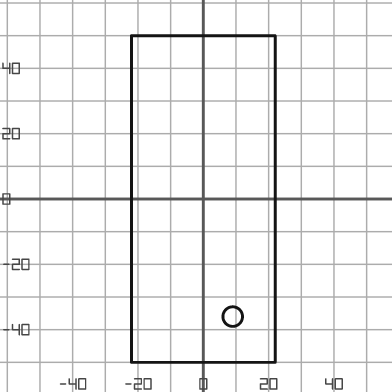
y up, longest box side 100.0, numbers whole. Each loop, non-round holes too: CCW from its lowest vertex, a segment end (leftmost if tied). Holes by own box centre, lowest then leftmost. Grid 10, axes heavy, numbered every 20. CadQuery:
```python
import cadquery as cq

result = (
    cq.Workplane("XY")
    .moveTo(-22.0, -50.0)
    .lineTo(22.0, -50.0)
    .lineTo(22.0, 50.0)
    .lineTo(-22.0, 50.0)
    .close()
    .moveTo(9.0, -36.0)
    .circle(3.0)
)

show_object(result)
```